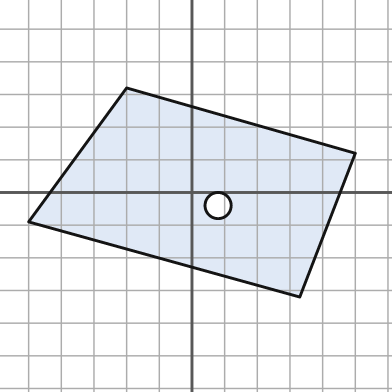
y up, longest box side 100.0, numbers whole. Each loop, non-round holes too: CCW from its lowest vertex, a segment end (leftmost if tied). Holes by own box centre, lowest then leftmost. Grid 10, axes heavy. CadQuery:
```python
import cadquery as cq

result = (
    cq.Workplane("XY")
    .moveTo(33.0, -32.0)
    .lineTo(50.0, 12.0)
    .lineTo(-20.0, 32.0)
    .lineTo(-50.0, -9.0)
    .close()
    .moveTo(8.0, -4.0)
    .circle(4.0)
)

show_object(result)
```